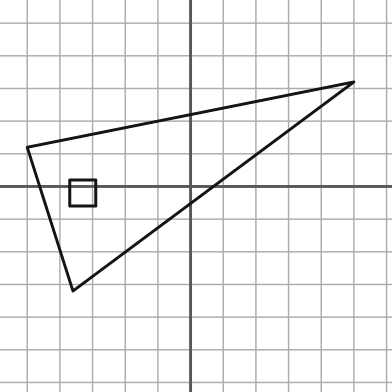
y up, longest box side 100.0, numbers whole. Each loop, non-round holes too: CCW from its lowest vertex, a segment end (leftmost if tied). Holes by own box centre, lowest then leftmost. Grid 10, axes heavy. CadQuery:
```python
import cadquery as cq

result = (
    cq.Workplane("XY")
    .moveTo(-36.0, -32.0)
    .lineTo(50.0, 32.0)
    .lineTo(-50.0, 12.0)
    .close()
    .moveTo(-37.0, -6.0)
    .lineTo(-29.0, -6.0)
    .lineTo(-29.0, 2.0)
    .lineTo(-37.0, 2.0)
    .close()
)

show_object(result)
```